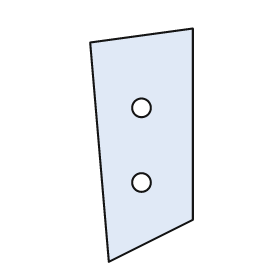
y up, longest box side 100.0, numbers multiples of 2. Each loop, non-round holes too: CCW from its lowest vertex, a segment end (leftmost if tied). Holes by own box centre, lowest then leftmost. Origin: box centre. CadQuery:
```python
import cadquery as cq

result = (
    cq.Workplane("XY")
    .moveTo(-14.0, -50.0)
    .lineTo(22.0, -32.0)
    .lineTo(22.0, 50.0)
    .lineTo(-22.0, 44.0)
    .close()
    .moveTo(0.0, -16.0)
    .circle(4.0)
    .moveTo(0.0, 16.0)
    .circle(4.0)
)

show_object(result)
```